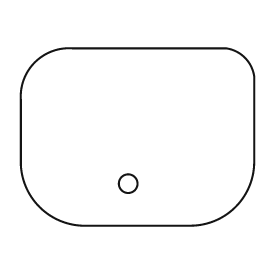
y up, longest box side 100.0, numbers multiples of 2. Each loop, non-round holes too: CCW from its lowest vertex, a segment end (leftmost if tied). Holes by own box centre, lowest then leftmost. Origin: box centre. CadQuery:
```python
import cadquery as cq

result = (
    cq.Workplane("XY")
    .moveTo(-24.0, -38.0)
    .lineTo(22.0, -38.0)
    .threePointArc((42.0, -30.0), (50.0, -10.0))
    .lineTo(50.0, 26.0)
    .threePointArc((46.0, 34.0), (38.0, 38.0))
    .lineTo(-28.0, 38.0)
    .threePointArc((-44.0, 32.0), (-50.0, 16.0))
    .lineTo(-50.0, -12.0)
    .threePointArc((-42.0, -30.0), (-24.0, -38.0))
    .close()
    .moveTo(-4.0, -20.0)
    .circle(4.0)
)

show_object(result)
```